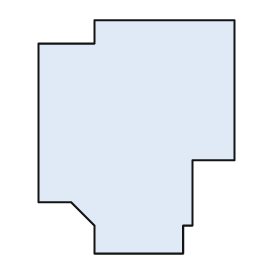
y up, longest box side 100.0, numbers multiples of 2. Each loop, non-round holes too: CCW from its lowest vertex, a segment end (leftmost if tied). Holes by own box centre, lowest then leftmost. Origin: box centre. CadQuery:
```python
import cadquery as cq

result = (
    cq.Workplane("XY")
    .moveTo(-18.0, -50.0)
    .lineTo(20.0, -50.0)
    .lineTo(20.0, -38.0)
    .lineTo(24.0, -38.0)
    .lineTo(24.0, -10.0)
    .lineTo(42.0, -10.0)
    .lineTo(42.0, 50.0)
    .lineTo(-18.0, 50.0)
    .lineTo(-18.0, 40.0)
    .lineTo(-42.0, 40.0)
    .lineTo(-42.0, -28.0)
    .lineTo(-28.0, -28.0)
    .lineTo(-18.0, -38.0)
    .close()
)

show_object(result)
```